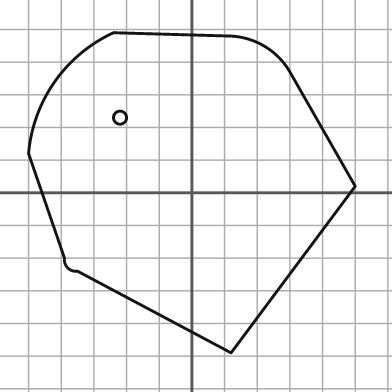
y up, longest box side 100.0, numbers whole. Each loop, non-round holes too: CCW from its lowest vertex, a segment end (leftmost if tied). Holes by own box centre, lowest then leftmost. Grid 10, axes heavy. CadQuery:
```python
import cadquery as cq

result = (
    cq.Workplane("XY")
    .moveTo(12.0, -49.0)
    .lineTo(50.0, 2.0)
    .lineTo(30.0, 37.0)
    .threePointArc((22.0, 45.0), (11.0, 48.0))
    .lineTo(-24.0, 49.0)
    .threePointArc((-42.0, 34.0), (-50.0, 12.0))
    .lineTo(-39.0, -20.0)
    .threePointArc((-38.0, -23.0), (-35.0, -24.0))
    .close()
    .moveTo(-22.0, 23.0)
    .circle(2.0)
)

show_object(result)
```